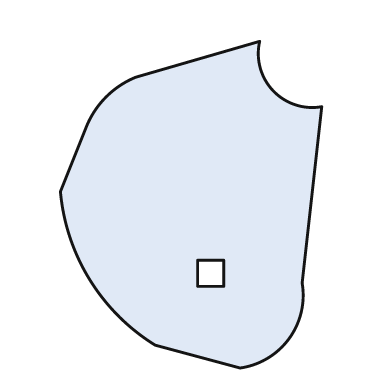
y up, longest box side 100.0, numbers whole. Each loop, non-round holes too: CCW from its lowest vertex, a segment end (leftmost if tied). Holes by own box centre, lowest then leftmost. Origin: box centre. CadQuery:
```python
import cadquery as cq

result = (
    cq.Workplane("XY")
    .moveTo(15.0, -50.0)
    .threePointArc((30.0, -41.0), (34.0, -24.0))
    .lineTo(40.0, 30.0)
    .threePointArc((25.0, 35.0), (21.0, 50.0))
    .lineTo(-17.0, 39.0)
    .threePointArc((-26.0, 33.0), (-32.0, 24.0))
    .lineTo(-40.0, 4.0)
    .threePointArc((-31.0, -23.0), (-11.0, -43.0))
    .close()
    .moveTo(2.0, -25.0)
    .lineTo(10.0, -25.0)
    .lineTo(10.0, -17.0)
    .lineTo(2.0, -17.0)
    .close()
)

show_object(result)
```